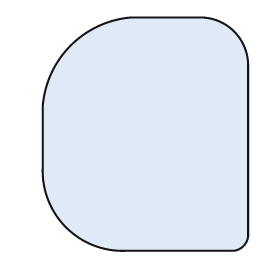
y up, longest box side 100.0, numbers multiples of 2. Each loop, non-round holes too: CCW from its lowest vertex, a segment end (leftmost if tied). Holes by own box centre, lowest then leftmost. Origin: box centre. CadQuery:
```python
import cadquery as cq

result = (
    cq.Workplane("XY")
    .moveTo(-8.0, -50.0)
    .lineTo(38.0, -50.0)
    .threePointArc((42.0, -48.0), (44.0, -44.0))
    .lineTo(44.0, 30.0)
    .threePointArc((38.0, 44.0), (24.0, 50.0))
    .lineTo(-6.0, 50.0)
    .threePointArc((-32.0, 38.0), (-44.0, 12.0))
    .lineTo(-44.0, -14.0)
    .threePointArc((-34.0, -40.0), (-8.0, -50.0))
    .close()
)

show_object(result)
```